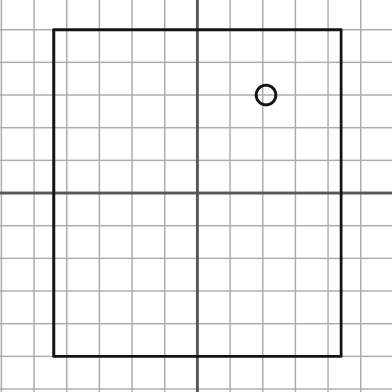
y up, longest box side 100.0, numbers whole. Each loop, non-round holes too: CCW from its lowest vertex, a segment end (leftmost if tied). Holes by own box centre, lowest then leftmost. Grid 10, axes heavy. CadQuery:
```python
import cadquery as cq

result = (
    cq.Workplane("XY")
    .moveTo(-44.0, -50.0)
    .lineTo(44.0, -50.0)
    .lineTo(44.0, 50.0)
    .lineTo(-44.0, 50.0)
    .close()
    .moveTo(21.0, 30.0)
    .circle(3.0)
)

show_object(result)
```